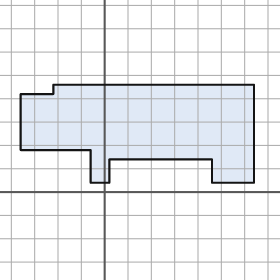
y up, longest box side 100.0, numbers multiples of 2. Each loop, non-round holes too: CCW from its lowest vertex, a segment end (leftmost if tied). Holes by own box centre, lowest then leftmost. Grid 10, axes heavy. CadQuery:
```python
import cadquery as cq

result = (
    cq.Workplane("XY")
    .moveTo(-6.0, 4.0)
    .lineTo(2.0, 4.0)
    .lineTo(2.0, 14.0)
    .lineTo(46.0, 14.0)
    .lineTo(46.0, 4.0)
    .lineTo(64.0, 4.0)
    .lineTo(64.0, 46.0)
    .lineTo(-22.0, 46.0)
    .lineTo(-22.0, 42.0)
    .lineTo(-36.0, 42.0)
    .lineTo(-36.0, 18.0)
    .lineTo(-6.0, 18.0)
    .close()
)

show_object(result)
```